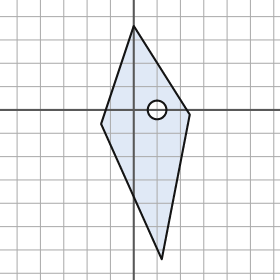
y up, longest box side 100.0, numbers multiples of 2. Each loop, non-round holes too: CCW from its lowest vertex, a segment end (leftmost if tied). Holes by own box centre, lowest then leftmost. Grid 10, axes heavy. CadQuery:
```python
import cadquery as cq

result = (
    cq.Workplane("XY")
    .moveTo(12.0, -64.0)
    .lineTo(24.0, -2.0)
    .lineTo(0.0, 36.0)
    .lineTo(-14.0, -6.0)
    .close()
    .moveTo(10.0, 0.0)
    .circle(4.0)
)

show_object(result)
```